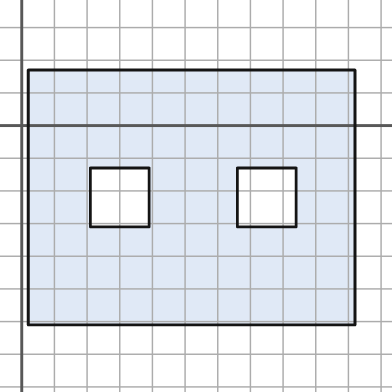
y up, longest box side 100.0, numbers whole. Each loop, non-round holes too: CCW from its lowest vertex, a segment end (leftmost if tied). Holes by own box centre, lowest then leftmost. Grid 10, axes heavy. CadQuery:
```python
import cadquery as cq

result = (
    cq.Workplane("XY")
    .moveTo(2.0, -61.0)
    .lineTo(102.0, -61.0)
    .lineTo(102.0, 17.0)
    .lineTo(2.0, 17.0)
    .close()
    .moveTo(21.0, -31.0)
    .lineTo(39.0, -31.0)
    .lineTo(39.0, -13.0)
    .lineTo(21.0, -13.0)
    .close()
    .moveTo(66.0, -31.0)
    .lineTo(84.0, -31.0)
    .lineTo(84.0, -13.0)
    .lineTo(66.0, -13.0)
    .close()
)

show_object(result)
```